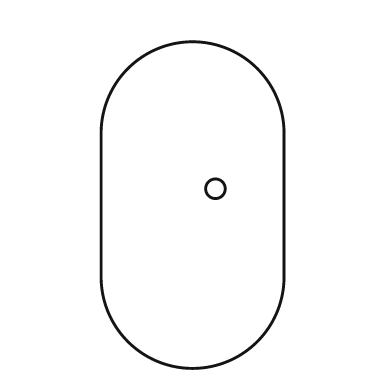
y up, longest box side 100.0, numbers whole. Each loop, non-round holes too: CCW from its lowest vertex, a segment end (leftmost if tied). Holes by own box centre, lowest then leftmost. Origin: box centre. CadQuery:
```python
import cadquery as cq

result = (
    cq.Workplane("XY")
    .moveTo(-28.0, -22.0)
    .threePointArc((0.0, -50.0), (28.0, -22.0))
    .lineTo(28.0, 22.0)
    .threePointArc((0.0, 50.0), (-28.0, 22.0))
    .close()
    .moveTo(7.0, 5.0)
    .circle(3.0)
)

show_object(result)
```